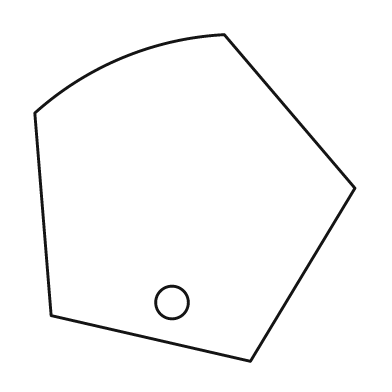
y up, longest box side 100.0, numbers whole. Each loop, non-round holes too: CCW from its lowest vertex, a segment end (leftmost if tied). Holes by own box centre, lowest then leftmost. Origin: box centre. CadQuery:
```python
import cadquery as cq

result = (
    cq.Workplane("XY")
    .moveTo(17.0, -50.0)
    .lineTo(49.0, 3.0)
    .lineTo(9.0, 50.0)
    .threePointArc((-22.0, 43.0), (-49.0, 26.0))
    .lineTo(-44.0, -36.0)
    .close()
    .moveTo(-7.0, -32.0)
    .circle(5.0)
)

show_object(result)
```